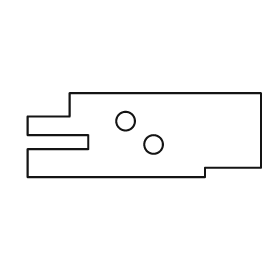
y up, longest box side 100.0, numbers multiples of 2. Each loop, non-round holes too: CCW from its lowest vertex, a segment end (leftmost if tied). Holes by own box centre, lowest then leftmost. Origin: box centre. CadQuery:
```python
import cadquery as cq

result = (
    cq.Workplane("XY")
    .moveTo(-50.0, -18.0)
    .lineTo(26.0, -18.0)
    .lineTo(26.0, -14.0)
    .lineTo(50.0, -14.0)
    .lineTo(50.0, 18.0)
    .lineTo(-32.0, 18.0)
    .lineTo(-32.0, 8.0)
    .lineTo(-50.0, 8.0)
    .lineTo(-50.0, 0.0)
    .lineTo(-24.0, 0.0)
    .lineTo(-24.0, -6.0)
    .lineTo(-50.0, -6.0)
    .close()
    .moveTo(4.0, -4.0)
    .circle(4.0)
    .moveTo(-8.0, 6.0)
    .circle(4.0)
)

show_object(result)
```